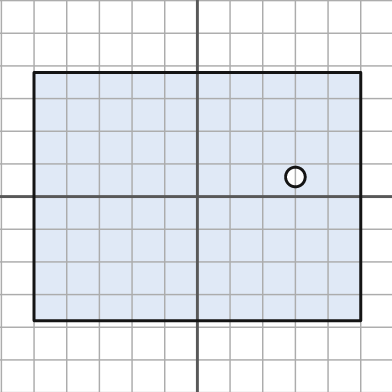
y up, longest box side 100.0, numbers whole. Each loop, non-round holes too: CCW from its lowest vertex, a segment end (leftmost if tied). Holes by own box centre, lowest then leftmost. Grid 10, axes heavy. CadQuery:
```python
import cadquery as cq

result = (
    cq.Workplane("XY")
    .moveTo(-50.0, -38.0)
    .lineTo(50.0, -38.0)
    .lineTo(50.0, 38.0)
    .lineTo(-50.0, 38.0)
    .close()
    .moveTo(30.0, 6.0)
    .circle(3.0)
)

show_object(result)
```